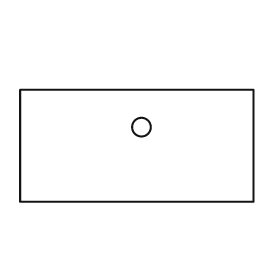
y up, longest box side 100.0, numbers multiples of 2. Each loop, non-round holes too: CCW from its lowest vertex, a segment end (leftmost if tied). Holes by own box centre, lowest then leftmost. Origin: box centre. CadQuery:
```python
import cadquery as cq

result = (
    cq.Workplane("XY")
    .moveTo(-50.0, -24.0)
    .lineTo(50.0, -24.0)
    .lineTo(50.0, 24.0)
    .lineTo(-50.0, 24.0)
    .close()
    .moveTo(2.0, 8.0)
    .circle(4.0)
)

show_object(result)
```